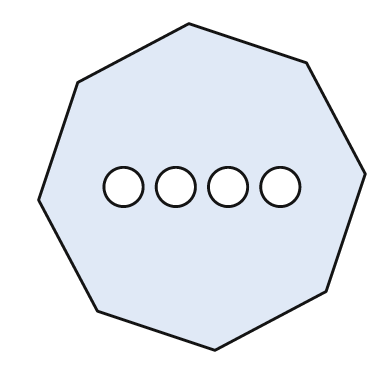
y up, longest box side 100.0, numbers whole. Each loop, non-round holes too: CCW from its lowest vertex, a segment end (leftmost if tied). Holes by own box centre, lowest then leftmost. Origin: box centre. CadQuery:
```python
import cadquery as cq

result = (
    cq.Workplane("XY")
    .moveTo(4.0, -50.0)
    .lineTo(38.0, -32.0)
    .lineTo(50.0, 4.0)
    .lineTo(32.0, 38.0)
    .lineTo(-4.0, 50.0)
    .lineTo(-38.0, 32.0)
    .lineTo(-50.0, -4.0)
    .lineTo(-32.0, -38.0)
    .close()
    .moveTo(-24.0, 0.0)
    .circle(6.0)
    .moveTo(-8.0, 0.0)
    .circle(6.0)
    .moveTo(8.0, 0.0)
    .circle(6.0)
    .moveTo(24.0, 0.0)
    .circle(6.0)
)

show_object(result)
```